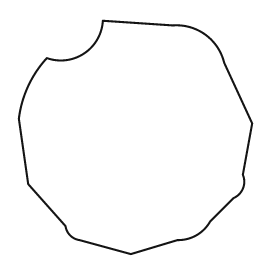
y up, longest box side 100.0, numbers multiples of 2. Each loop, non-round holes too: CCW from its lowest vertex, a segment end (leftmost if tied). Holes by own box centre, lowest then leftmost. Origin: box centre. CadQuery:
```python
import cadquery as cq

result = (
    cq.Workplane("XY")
    .moveTo(-2.0, -50.0)
    .lineTo(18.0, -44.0)
    .threePointArc((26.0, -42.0), (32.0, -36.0))
    .lineTo(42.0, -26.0)
    .threePointArc((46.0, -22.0), (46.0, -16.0))
    .lineTo(50.0, 6.0)
    .lineTo(38.0, 32.0)
    .threePointArc((30.0, 44.0), (16.0, 48.0))
    .lineTo(-14.0, 50.0)
    .threePointArc((-22.0, 36.0), (-38.0, 34.0))
    .threePointArc((-46.0, 22.0), (-50.0, 8.0))
    .lineTo(-46.0, -20.0)
    .lineTo(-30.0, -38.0)
    .threePointArc((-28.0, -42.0), (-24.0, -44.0))
    .close()
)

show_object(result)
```